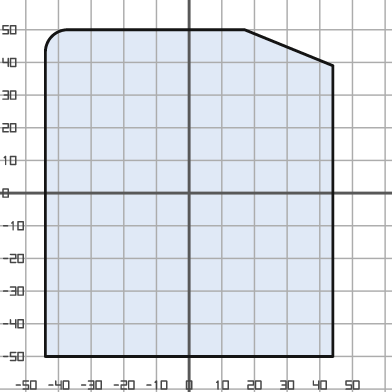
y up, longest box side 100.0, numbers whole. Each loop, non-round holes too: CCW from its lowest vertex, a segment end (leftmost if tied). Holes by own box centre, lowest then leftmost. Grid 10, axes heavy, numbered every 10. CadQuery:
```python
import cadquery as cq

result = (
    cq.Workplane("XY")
    .moveTo(-44.0, -50.0)
    .lineTo(44.0, -50.0)
    .lineTo(44.0, 39.0)
    .lineTo(17.0, 50.0)
    .lineTo(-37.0, 50.0)
    .threePointArc((-42.0, 48.0), (-44.0, 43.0))
    .close()
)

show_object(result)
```